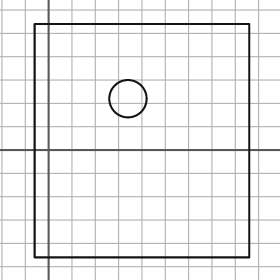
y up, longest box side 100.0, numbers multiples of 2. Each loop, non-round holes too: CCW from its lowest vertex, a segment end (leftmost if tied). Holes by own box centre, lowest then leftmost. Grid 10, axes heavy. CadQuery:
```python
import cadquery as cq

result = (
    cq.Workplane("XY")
    .moveTo(-6.0, -46.0)
    .lineTo(86.0, -46.0)
    .lineTo(86.0, 54.0)
    .lineTo(-6.0, 54.0)
    .close()
    .moveTo(34.0, 22.0)
    .circle(8.0)
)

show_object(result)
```